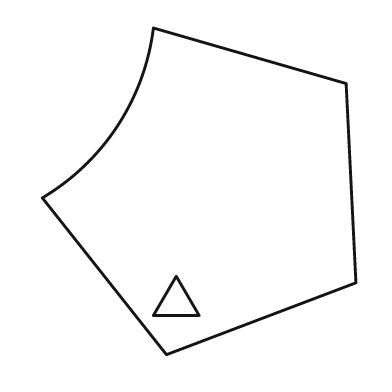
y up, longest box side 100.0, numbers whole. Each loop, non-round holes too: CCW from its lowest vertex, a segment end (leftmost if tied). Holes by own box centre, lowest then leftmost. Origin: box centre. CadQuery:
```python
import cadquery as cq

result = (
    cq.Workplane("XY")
    .moveTo(-10.0, -50.0)
    .lineTo(48.0, -28.0)
    .lineTo(45.0, 33.0)
    .lineTo(-14.0, 50.0)
    .threePointArc((-25.0, 20.0), (-48.0, -2.0))
    .close()
    .moveTo(-14.0, -38.0)
    .lineTo(0.0, -38.0)
    .lineTo(-7.0, -26.0)
    .close()
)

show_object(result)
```